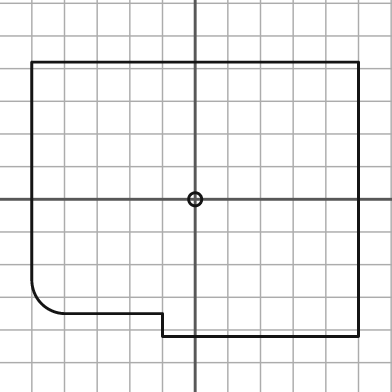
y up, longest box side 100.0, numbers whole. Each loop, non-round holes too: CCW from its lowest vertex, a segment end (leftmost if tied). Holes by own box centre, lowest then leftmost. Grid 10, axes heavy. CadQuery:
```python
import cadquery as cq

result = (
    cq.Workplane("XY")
    .moveTo(-10.0, -42.0)
    .lineTo(50.0, -42.0)
    .lineTo(50.0, 42.0)
    .lineTo(-50.0, 42.0)
    .lineTo(-50.0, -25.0)
    .threePointArc((-47.0, -32.0), (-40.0, -35.0))
    .lineTo(-10.0, -35.0)
    .close()
    .moveTo(0.0, 0.0)
    .circle(2.0)
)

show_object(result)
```